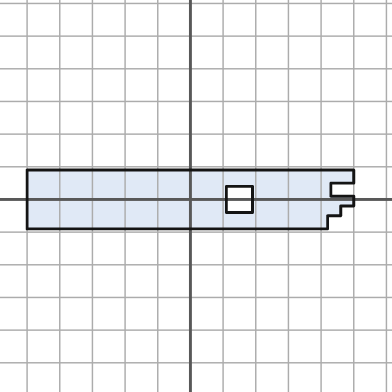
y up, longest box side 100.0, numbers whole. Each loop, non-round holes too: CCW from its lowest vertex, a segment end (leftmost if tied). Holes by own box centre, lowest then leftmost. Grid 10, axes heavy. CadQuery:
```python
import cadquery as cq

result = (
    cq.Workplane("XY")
    .moveTo(-50.0, -9.0)
    .lineTo(42.0, -9.0)
    .lineTo(42.0, -5.0)
    .lineTo(46.0, -5.0)
    .lineTo(46.0, -2.0)
    .lineTo(50.0, -2.0)
    .lineTo(50.0, 1.0)
    .lineTo(43.0, 1.0)
    .lineTo(43.0, 5.0)
    .lineTo(50.0, 5.0)
    .lineTo(50.0, 9.0)
    .lineTo(-50.0, 9.0)
    .close()
    .moveTo(11.0, -4.0)
    .lineTo(19.0, -4.0)
    .lineTo(19.0, 4.0)
    .lineTo(11.0, 4.0)
    .close()
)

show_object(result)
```